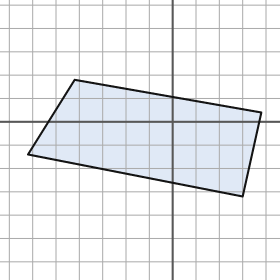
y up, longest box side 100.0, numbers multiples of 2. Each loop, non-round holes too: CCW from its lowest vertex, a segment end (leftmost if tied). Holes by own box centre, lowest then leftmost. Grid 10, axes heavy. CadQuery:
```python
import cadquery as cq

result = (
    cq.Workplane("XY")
    .moveTo(30.0, -32.0)
    .lineTo(38.0, 4.0)
    .lineTo(-42.0, 18.0)
    .lineTo(-62.0, -14.0)
    .close()
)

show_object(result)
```